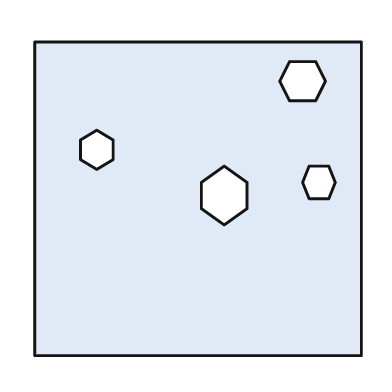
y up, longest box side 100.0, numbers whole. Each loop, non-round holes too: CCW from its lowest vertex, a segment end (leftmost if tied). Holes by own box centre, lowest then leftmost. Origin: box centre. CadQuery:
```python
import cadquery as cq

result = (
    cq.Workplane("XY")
    .moveTo(-50.0, -48.0)
    .lineTo(50.0, -48.0)
    .lineTo(50.0, 48.0)
    .lineTo(-50.0, 48.0)
    .close()
    .moveTo(8.0, -8.0)
    .lineTo(15.0, -3.0)
    .lineTo(15.0, 5.0)
    .lineTo(8.0, 10.0)
    .lineTo(1.0, 5.0)
    .lineTo(1.0, -3.0)
    .close()
    .moveTo(34.0, 0.0)
    .lineTo(40.0, 0.0)
    .lineTo(42.0, 5.0)
    .lineTo(40.0, 10.0)
    .lineTo(34.0, 10.0)
    .lineTo(32.0, 5.0)
    .close()
    .moveTo(-31.0, 9.0)
    .lineTo(-26.0, 12.0)
    .lineTo(-26.0, 18.0)
    .lineTo(-31.0, 21.0)
    .lineTo(-36.0, 18.0)
    .lineTo(-36.0, 12.0)
    .close()
    .moveTo(28.0, 30.0)
    .lineTo(36.0, 30.0)
    .lineTo(39.0, 36.0)
    .lineTo(36.0, 42.0)
    .lineTo(28.0, 42.0)
    .lineTo(25.0, 36.0)
    .close()
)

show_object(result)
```